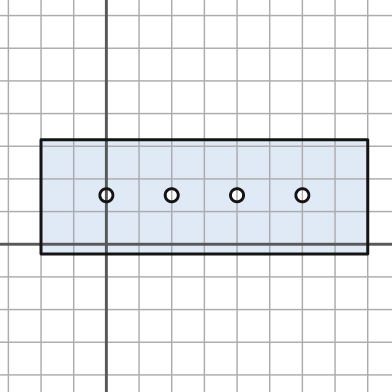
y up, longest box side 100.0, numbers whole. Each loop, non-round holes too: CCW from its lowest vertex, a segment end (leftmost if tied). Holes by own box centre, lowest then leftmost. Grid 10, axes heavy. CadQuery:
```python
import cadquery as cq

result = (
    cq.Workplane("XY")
    .moveTo(-20.0, -3.0)
    .lineTo(80.0, -3.0)
    .lineTo(80.0, 32.0)
    .lineTo(-20.0, 32.0)
    .close()
    .moveTo(0.0, 15.0)
    .circle(2.0)
    .moveTo(20.0, 15.0)
    .circle(2.0)
    .moveTo(40.0, 15.0)
    .circle(2.0)
    .moveTo(60.0, 15.0)
    .circle(2.0)
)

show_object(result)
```